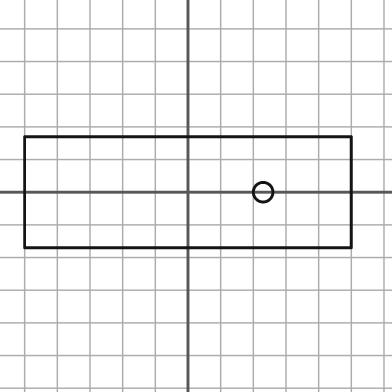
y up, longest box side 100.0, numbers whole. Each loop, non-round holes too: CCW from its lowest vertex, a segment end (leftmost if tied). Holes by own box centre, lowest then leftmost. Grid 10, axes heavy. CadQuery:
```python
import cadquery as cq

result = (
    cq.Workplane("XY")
    .moveTo(-50.0, -17.0)
    .lineTo(50.0, -17.0)
    .lineTo(50.0, 17.0)
    .lineTo(-50.0, 17.0)
    .close()
    .moveTo(23.0, 0.0)
    .circle(3.0)
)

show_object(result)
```